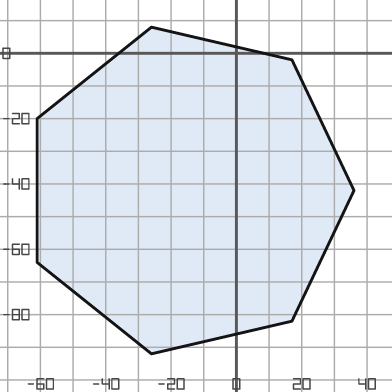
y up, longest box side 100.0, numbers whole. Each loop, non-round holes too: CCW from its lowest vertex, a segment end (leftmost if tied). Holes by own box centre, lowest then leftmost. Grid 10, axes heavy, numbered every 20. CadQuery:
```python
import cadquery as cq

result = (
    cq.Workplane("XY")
    .moveTo(-26.0, -92.0)
    .lineTo(17.0, -82.0)
    .lineTo(36.0, -42.0)
    .lineTo(17.0, -2.0)
    .lineTo(-26.0, 8.0)
    .lineTo(-61.0, -20.0)
    .lineTo(-61.0, -64.0)
    .close()
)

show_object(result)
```